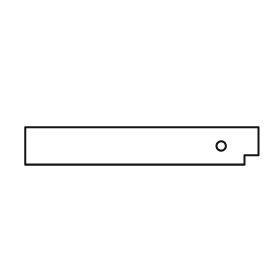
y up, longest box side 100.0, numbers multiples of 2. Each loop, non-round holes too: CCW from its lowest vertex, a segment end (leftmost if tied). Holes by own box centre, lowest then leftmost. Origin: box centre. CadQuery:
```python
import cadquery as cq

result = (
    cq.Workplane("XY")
    .moveTo(-50.0, -8.0)
    .lineTo(44.0, -8.0)
    .lineTo(44.0, -4.0)
    .lineTo(50.0, -4.0)
    .lineTo(50.0, 8.0)
    .lineTo(-50.0, 8.0)
    .close()
    .moveTo(34.0, 0.0)
    .circle(2.0)
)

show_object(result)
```